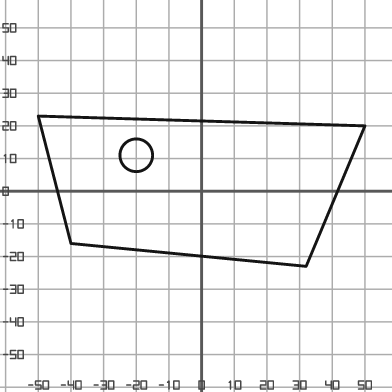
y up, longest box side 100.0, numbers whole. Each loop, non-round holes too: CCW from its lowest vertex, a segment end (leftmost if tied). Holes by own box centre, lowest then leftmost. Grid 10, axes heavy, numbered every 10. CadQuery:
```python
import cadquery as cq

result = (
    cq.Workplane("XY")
    .moveTo(32.0, -23.0)
    .lineTo(50.0, 20.0)
    .lineTo(-50.0, 23.0)
    .lineTo(-40.0, -16.0)
    .close()
    .moveTo(-20.0, 11.0)
    .circle(5.0)
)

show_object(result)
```